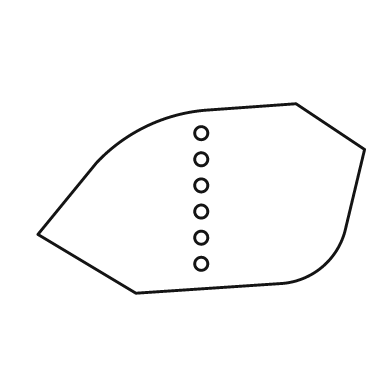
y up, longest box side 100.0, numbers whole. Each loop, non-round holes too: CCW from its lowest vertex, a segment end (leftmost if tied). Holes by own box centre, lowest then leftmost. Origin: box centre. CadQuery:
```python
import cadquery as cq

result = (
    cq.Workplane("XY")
    .moveTo(-20.0, -29.0)
    .lineTo(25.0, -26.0)
    .threePointArc((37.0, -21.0), (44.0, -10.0))
    .lineTo(50.0, 15.0)
    .lineTo(29.0, 29.0)
    .lineTo(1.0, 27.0)
    .threePointArc((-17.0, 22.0), (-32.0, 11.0))
    .lineTo(-50.0, -11.0)
    .close()
    .moveTo(0.0, -20.0)
    .circle(2.0)
    .moveTo(0.0, -12.0)
    .circle(2.0)
    .moveTo(0.0, -4.0)
    .circle(2.0)
    .moveTo(0.0, 4.0)
    .circle(2.0)
    .moveTo(0.0, 12.0)
    .circle(2.0)
    .moveTo(0.0, 20.0)
    .circle(2.0)
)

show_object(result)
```